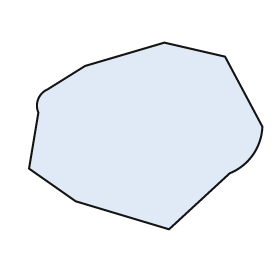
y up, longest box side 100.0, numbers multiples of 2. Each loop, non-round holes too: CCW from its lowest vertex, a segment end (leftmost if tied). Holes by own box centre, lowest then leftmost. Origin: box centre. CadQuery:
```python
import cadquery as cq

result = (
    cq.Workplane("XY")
    .moveTo(10.0, -40.0)
    .lineTo(36.0, -16.0)
    .threePointArc((46.0, -8.0), (50.0, 4.0))
    .lineTo(34.0, 34.0)
    .lineTo(8.0, 40.0)
    .lineTo(-26.0, 30.0)
    .lineTo(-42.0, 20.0)
    .threePointArc((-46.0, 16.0), (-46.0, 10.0))
    .lineTo(-50.0, -14.0)
    .lineTo(-30.0, -28.0)
    .close()
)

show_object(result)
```